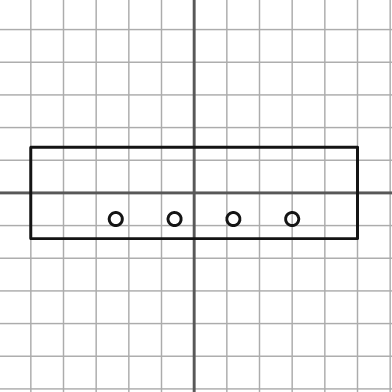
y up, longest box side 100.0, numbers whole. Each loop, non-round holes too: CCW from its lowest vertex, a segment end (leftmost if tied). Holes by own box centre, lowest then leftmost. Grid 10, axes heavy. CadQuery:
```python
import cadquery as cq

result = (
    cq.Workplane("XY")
    .moveTo(-50.0, -14.0)
    .lineTo(50.0, -14.0)
    .lineTo(50.0, 14.0)
    .lineTo(-50.0, 14.0)
    .close()
    .moveTo(-24.0, -8.0)
    .circle(2.0)
    .moveTo(-6.0, -8.0)
    .circle(2.0)
    .moveTo(12.0, -8.0)
    .circle(2.0)
    .moveTo(30.0, -8.0)
    .circle(2.0)
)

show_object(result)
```